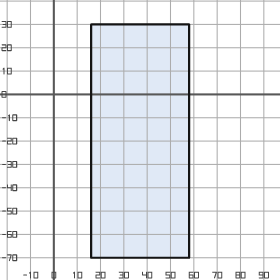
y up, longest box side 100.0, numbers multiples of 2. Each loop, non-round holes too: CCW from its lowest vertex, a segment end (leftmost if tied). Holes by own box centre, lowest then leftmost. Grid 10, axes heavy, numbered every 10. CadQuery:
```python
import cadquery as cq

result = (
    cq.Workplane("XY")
    .moveTo(16.0, -70.0)
    .lineTo(58.0, -70.0)
    .lineTo(58.0, 30.0)
    .lineTo(16.0, 30.0)
    .close()
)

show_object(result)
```